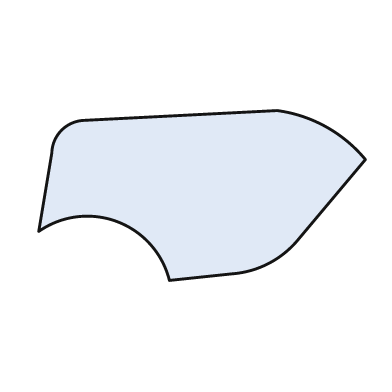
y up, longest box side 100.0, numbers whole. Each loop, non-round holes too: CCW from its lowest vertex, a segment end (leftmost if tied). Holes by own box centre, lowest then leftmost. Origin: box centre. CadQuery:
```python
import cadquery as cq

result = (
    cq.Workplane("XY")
    .moveTo(-10.0, -26.0)
    .lineTo(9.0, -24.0)
    .threePointArc((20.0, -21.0), (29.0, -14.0))
    .lineTo(50.0, 11.0)
    .threePointArc((38.0, 21.0), (23.0, 26.0))
    .lineTo(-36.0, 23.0)
    .threePointArc((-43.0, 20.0), (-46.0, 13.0))
    .lineTo(-50.0, -11.0)
    .threePointArc((-26.0, -8.0), (-10.0, -26.0))
    .close()
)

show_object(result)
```